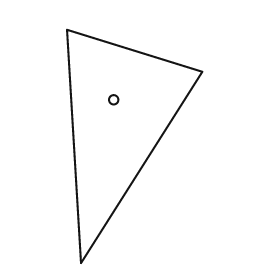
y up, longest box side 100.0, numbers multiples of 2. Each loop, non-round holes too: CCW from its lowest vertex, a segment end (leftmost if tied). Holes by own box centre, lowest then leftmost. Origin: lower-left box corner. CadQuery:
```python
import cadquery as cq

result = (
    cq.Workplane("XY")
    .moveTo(6.0, 0.0)
    .lineTo(58.0, 82.0)
    .lineTo(0.0, 100.0)
    .close()
    .moveTo(20.0, 70.0)
    .circle(2.0)
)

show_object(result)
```